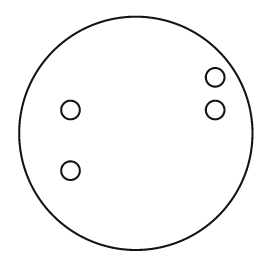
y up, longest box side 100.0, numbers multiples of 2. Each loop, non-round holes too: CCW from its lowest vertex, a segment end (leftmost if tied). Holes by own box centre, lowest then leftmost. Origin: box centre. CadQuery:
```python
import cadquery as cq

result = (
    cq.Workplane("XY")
    .moveTo(0.0, 0.0)
    .circle(50.0)
    .moveTo(-28.0, -16.0)
    .circle(4.0)
    .moveTo(-28.0, 10.0)
    .circle(4.0)
    .moveTo(34.0, 10.0)
    .circle(4.0)
    .moveTo(34.0, 24.0)
    .circle(4.0)
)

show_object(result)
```